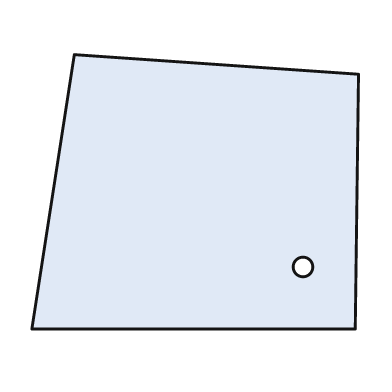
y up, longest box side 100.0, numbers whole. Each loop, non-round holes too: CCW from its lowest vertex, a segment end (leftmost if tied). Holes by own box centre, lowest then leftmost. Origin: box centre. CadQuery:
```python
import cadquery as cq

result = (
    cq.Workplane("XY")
    .moveTo(-50.0, -42.0)
    .lineTo(49.0, -42.0)
    .lineTo(50.0, 36.0)
    .lineTo(-37.0, 42.0)
    .close()
    .moveTo(33.0, -23.0)
    .circle(3.0)
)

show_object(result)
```